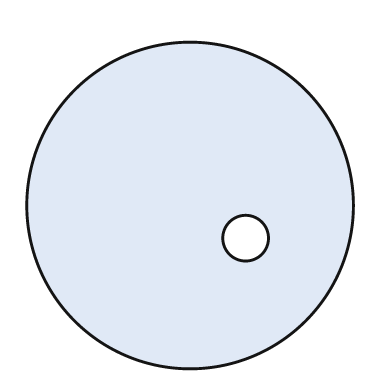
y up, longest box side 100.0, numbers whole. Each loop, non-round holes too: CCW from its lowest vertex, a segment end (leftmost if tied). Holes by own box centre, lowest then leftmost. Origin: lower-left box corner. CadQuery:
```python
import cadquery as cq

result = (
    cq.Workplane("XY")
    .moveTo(50.0, 50.0)
    .circle(50.0)
    .moveTo(67.0, 40.0)
    .circle(7.0)
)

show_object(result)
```